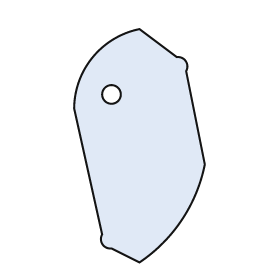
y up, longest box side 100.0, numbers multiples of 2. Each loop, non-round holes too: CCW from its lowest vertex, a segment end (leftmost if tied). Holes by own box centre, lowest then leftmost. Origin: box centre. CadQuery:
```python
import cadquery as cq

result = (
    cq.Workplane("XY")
    .moveTo(0.0, -50.0)
    .threePointArc((18.0, -32.0), (28.0, -8.0))
    .lineTo(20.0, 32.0)
    .threePointArc((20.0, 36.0), (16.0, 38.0))
    .lineTo(0.0, 50.0)
    .threePointArc((-20.0, 38.0), (-28.0, 16.0))
    .lineTo(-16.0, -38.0)
    .threePointArc((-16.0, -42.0), (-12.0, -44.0))
    .close()
    .moveTo(-12.0, 22.0)
    .circle(4.0)
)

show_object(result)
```